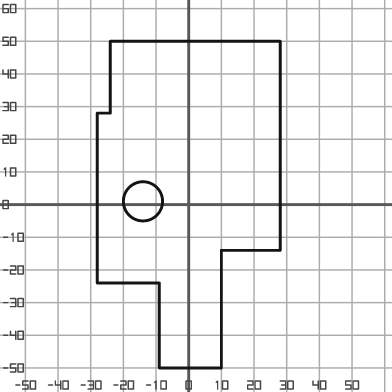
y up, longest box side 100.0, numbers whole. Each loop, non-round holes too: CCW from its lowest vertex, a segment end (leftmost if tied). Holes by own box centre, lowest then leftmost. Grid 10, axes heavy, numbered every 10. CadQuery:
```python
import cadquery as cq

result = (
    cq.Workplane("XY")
    .moveTo(-9.0, -50.0)
    .lineTo(10.0, -50.0)
    .lineTo(10.0, -14.0)
    .lineTo(28.0, -14.0)
    .lineTo(28.0, 50.0)
    .lineTo(-24.0, 50.0)
    .lineTo(-24.0, 28.0)
    .lineTo(-28.0, 28.0)
    .lineTo(-28.0, -24.0)
    .lineTo(-9.0, -24.0)
    .close()
    .moveTo(-14.0, 1.0)
    .circle(6.0)
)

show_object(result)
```